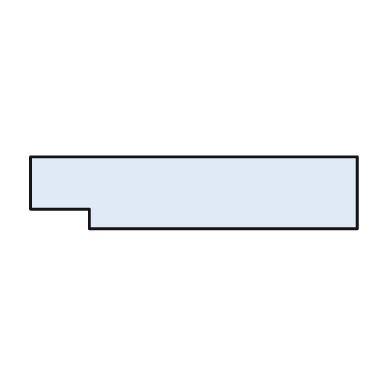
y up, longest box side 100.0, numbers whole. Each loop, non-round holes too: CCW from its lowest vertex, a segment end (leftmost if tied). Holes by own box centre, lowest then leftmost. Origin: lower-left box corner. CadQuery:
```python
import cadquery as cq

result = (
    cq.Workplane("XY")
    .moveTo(18.0, 0.0)
    .lineTo(100.0, 0.0)
    .lineTo(100.0, 22.0)
    .lineTo(0.0, 22.0)
    .lineTo(0.0, 6.0)
    .lineTo(18.0, 6.0)
    .close()
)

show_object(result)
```